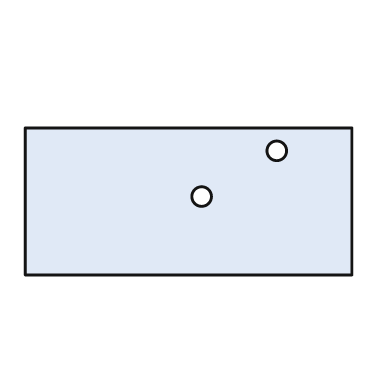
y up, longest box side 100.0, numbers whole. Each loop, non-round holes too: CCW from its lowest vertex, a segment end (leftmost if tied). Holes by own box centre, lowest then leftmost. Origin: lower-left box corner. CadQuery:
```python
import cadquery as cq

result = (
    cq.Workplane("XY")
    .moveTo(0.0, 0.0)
    .lineTo(100.0, 0.0)
    .lineTo(100.0, 45.0)
    .lineTo(0.0, 45.0)
    .close()
    .moveTo(54.0, 24.0)
    .circle(3.0)
    .moveTo(77.0, 38.0)
    .circle(3.0)
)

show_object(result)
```